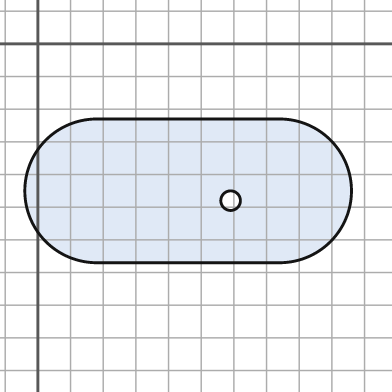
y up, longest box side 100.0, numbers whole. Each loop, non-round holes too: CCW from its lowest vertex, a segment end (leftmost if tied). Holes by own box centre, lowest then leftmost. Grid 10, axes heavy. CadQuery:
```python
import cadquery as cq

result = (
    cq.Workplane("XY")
    .moveTo(18.0, -67.0)
    .lineTo(74.0, -67.0)
    .threePointArc((96.0, -45.0), (74.0, -23.0))
    .lineTo(18.0, -23.0)
    .threePointArc((-4.0, -45.0), (18.0, -67.0))
    .close()
    .moveTo(59.0, -48.0)
    .circle(3.0)
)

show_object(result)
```